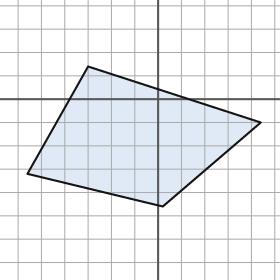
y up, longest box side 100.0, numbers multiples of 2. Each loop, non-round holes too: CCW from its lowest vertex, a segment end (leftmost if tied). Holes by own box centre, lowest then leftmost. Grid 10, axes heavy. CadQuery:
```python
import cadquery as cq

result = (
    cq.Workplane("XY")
    .moveTo(2.0, -46.0)
    .lineTo(44.0, -10.0)
    .lineTo(-30.0, 14.0)
    .lineTo(-56.0, -32.0)
    .close()
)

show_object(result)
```